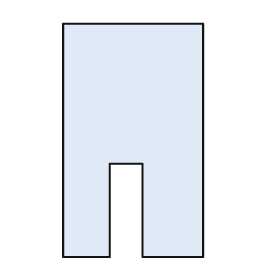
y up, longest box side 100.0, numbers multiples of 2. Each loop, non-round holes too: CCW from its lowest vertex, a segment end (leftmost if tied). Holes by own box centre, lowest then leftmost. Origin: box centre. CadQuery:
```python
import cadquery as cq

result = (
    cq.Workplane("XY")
    .moveTo(-30.0, -50.0)
    .lineTo(-10.0, -50.0)
    .lineTo(-10.0, -10.0)
    .lineTo(4.0, -10.0)
    .lineTo(4.0, -50.0)
    .lineTo(30.0, -50.0)
    .lineTo(30.0, 50.0)
    .lineTo(-30.0, 50.0)
    .close()
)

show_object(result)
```